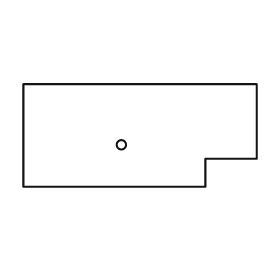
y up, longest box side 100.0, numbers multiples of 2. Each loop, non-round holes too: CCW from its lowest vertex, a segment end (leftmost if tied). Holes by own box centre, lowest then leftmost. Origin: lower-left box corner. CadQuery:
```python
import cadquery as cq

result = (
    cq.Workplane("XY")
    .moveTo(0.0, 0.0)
    .lineTo(78.0, 0.0)
    .lineTo(78.0, 12.0)
    .lineTo(100.0, 12.0)
    .lineTo(100.0, 44.0)
    .lineTo(0.0, 44.0)
    .close()
    .moveTo(42.0, 18.0)
    .circle(2.0)
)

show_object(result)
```